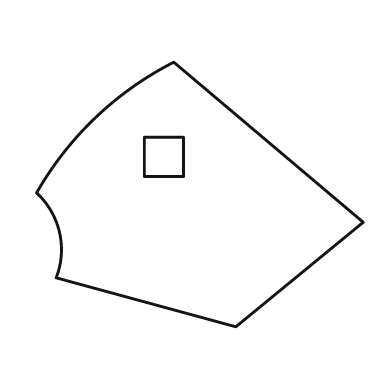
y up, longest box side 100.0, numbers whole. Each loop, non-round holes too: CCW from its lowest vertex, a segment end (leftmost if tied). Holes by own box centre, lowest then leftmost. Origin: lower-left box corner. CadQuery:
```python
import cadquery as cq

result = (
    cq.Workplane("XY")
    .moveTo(61.0, 0.0)
    .lineTo(100.0, 32.0)
    .lineTo(42.0, 81.0)
    .threePointArc((18.0, 64.0), (0.0, 41.0))
    .threePointArc((7.0, 29.0), (6.0, 15.0))
    .close()
    .moveTo(33.0, 46.0)
    .lineTo(45.0, 46.0)
    .lineTo(45.0, 58.0)
    .lineTo(33.0, 58.0)
    .close()
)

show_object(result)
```